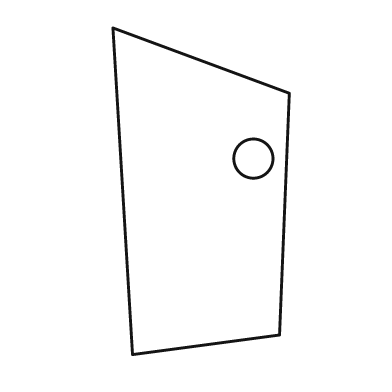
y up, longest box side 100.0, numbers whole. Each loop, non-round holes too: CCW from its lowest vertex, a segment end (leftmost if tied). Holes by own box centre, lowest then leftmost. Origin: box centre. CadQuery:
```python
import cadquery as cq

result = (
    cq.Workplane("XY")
    .moveTo(-21.0, -50.0)
    .lineTo(24.0, -44.0)
    .lineTo(27.0, 30.0)
    .lineTo(-27.0, 50.0)
    .close()
    .moveTo(16.0, 10.0)
    .circle(6.0)
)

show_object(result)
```